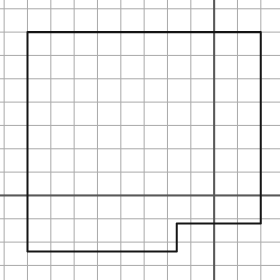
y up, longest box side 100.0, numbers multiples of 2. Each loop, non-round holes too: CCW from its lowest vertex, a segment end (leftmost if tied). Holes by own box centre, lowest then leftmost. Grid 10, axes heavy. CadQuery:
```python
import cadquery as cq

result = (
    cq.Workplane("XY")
    .moveTo(-80.0, -24.0)
    .lineTo(-16.0, -24.0)
    .lineTo(-16.0, -12.0)
    .lineTo(20.0, -12.0)
    .lineTo(20.0, 70.0)
    .lineTo(-80.0, 70.0)
    .close()
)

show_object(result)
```